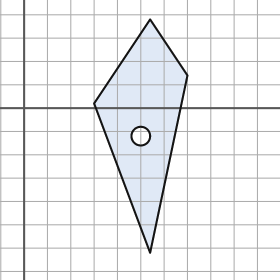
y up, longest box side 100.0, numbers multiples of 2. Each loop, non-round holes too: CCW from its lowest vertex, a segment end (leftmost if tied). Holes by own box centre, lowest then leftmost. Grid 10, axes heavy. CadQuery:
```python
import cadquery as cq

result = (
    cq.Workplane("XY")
    .moveTo(54.0, -62.0)
    .lineTo(70.0, 14.0)
    .lineTo(54.0, 38.0)
    .lineTo(30.0, 2.0)
    .close()
    .moveTo(50.0, -12.0)
    .circle(4.0)
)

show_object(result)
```